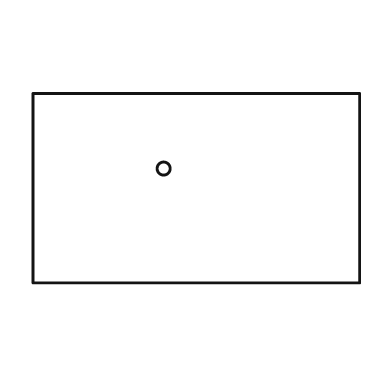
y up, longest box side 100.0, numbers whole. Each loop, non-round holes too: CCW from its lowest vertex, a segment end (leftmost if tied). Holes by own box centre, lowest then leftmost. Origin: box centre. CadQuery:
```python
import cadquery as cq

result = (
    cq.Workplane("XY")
    .moveTo(-50.0, -29.0)
    .lineTo(50.0, -29.0)
    .lineTo(50.0, 29.0)
    .lineTo(-50.0, 29.0)
    .close()
    .moveTo(-10.0, 6.0)
    .circle(2.0)
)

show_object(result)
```